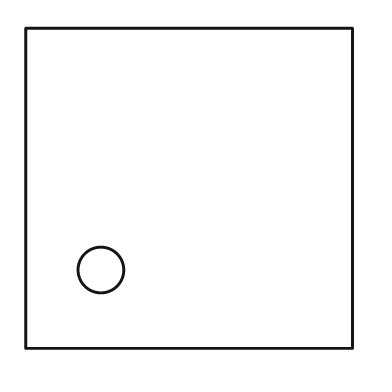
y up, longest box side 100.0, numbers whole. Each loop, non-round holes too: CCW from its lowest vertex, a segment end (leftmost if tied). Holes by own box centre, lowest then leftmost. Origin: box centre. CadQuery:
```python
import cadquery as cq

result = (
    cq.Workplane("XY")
    .moveTo(-50.0, -49.0)
    .lineTo(50.0, -49.0)
    .lineTo(50.0, 49.0)
    .lineTo(-50.0, 49.0)
    .close()
    .moveTo(-27.0, -25.0)
    .circle(7.0)
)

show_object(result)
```